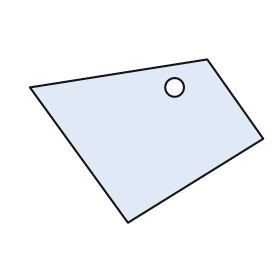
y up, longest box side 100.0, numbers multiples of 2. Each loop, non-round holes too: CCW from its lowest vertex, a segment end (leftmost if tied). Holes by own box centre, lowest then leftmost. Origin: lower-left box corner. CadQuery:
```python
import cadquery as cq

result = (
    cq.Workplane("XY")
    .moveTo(42.0, 0.0)
    .lineTo(100.0, 36.0)
    .lineTo(76.0, 70.0)
    .lineTo(0.0, 58.0)
    .close()
    .moveTo(62.0, 58.0)
    .circle(4.0)
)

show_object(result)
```